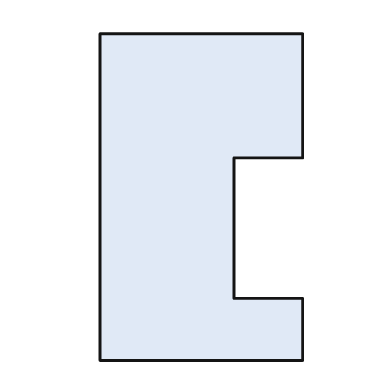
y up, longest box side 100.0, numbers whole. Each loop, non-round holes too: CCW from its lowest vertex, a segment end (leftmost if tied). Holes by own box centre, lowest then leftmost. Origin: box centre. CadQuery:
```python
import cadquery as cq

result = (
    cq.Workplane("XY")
    .moveTo(-31.0, -50.0)
    .lineTo(31.0, -50.0)
    .lineTo(31.0, -31.0)
    .lineTo(10.0, -31.0)
    .lineTo(10.0, 12.0)
    .lineTo(31.0, 12.0)
    .lineTo(31.0, 50.0)
    .lineTo(-31.0, 50.0)
    .close()
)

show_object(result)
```